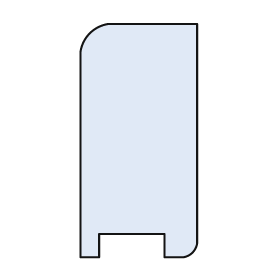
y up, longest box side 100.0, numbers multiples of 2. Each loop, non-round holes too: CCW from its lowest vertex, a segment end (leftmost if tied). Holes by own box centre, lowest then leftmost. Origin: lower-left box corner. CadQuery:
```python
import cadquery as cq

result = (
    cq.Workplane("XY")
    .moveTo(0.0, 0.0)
    .lineTo(8.0, 0.0)
    .lineTo(8.0, 10.0)
    .lineTo(36.0, 10.0)
    .lineTo(36.0, 0.0)
    .lineTo(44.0, 0.0)
    .threePointArc((48.0, 2.0), (50.0, 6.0))
    .lineTo(50.0, 100.0)
    .lineTo(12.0, 100.0)
    .threePointArc((4.0, 96.0), (0.0, 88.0))
    .close()
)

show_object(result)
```